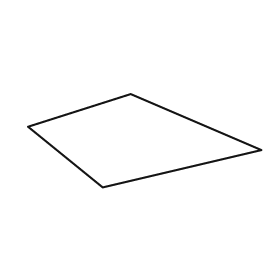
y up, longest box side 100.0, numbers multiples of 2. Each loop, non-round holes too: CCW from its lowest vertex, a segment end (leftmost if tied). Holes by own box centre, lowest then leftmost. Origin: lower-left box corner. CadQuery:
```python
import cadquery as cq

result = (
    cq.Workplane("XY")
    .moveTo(32.0, 0.0)
    .lineTo(100.0, 16.0)
    .lineTo(44.0, 40.0)
    .lineTo(0.0, 26.0)
    .close()
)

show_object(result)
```